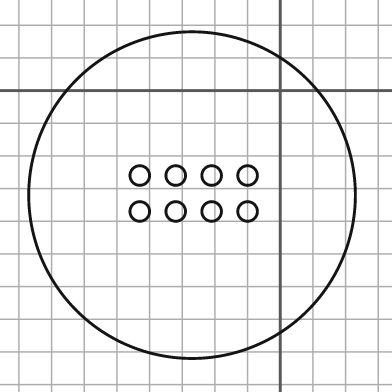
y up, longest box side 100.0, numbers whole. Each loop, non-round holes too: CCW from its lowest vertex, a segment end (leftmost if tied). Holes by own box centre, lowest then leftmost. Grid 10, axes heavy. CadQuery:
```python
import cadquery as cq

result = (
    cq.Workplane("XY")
    .moveTo(-27.0, -32.0)
    .circle(50.0)
    .moveTo(-43.0, -37.0)
    .circle(3.0)
    .moveTo(-32.0, -37.0)
    .circle(3.0)
    .moveTo(-21.0, -37.0)
    .circle(3.0)
    .moveTo(-10.0, -37.0)
    .circle(3.0)
    .moveTo(-43.0, -26.0)
    .circle(3.0)
    .moveTo(-32.0, -26.0)
    .circle(3.0)
    .moveTo(-21.0, -26.0)
    .circle(3.0)
    .moveTo(-10.0, -26.0)
    .circle(3.0)
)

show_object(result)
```